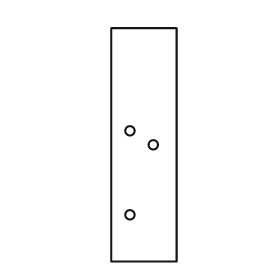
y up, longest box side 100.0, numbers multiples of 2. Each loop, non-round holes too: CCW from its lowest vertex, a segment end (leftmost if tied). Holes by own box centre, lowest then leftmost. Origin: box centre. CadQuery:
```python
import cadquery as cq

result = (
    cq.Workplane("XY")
    .moveTo(-14.0, -50.0)
    .lineTo(14.0, -50.0)
    .lineTo(14.0, 50.0)
    .lineTo(-14.0, 50.0)
    .close()
    .moveTo(-6.0, -30.0)
    .circle(2.0)
    .moveTo(4.0, 0.0)
    .circle(2.0)
    .moveTo(-6.0, 6.0)
    .circle(2.0)
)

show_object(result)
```